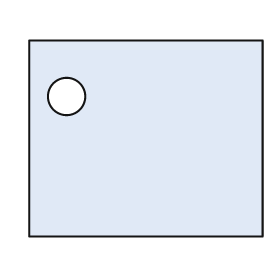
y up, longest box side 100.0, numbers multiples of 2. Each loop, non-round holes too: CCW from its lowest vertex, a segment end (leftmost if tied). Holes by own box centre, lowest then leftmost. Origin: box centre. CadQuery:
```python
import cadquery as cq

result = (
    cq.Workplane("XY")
    .moveTo(-50.0, -42.0)
    .lineTo(50.0, -42.0)
    .lineTo(50.0, 42.0)
    .lineTo(-50.0, 42.0)
    .close()
    .moveTo(-34.0, 18.0)
    .circle(8.0)
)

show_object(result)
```